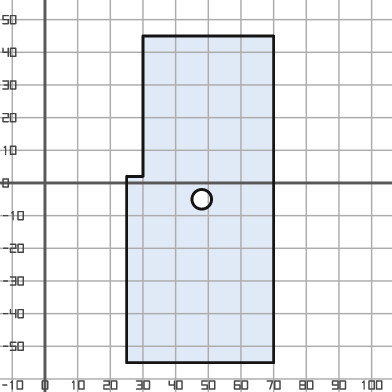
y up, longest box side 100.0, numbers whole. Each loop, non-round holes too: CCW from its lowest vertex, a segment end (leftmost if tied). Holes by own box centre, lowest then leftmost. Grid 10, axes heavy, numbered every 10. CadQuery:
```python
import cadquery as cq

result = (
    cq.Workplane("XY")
    .moveTo(25.0, -55.0)
    .lineTo(70.0, -55.0)
    .lineTo(70.0, 45.0)
    .lineTo(30.0, 45.0)
    .lineTo(30.0, 2.0)
    .lineTo(25.0, 2.0)
    .close()
    .moveTo(48.0, -5.0)
    .circle(3.0)
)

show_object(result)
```